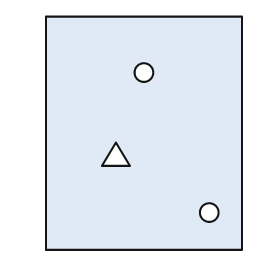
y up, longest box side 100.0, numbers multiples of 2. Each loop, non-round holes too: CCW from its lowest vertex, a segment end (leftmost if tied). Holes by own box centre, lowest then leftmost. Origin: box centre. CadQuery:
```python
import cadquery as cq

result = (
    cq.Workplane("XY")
    .moveTo(-42.0, -50.0)
    .lineTo(42.0, -50.0)
    .lineTo(42.0, 50.0)
    .lineTo(-42.0, 50.0)
    .close()
    .moveTo(28.0, -34.0)
    .circle(4.0)
    .moveTo(-18.0, -14.0)
    .lineTo(-6.0, -14.0)
    .lineTo(-12.0, -4.0)
    .close()
    .moveTo(0.0, 26.0)
    .circle(4.0)
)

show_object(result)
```